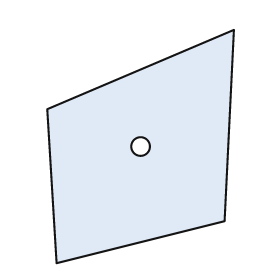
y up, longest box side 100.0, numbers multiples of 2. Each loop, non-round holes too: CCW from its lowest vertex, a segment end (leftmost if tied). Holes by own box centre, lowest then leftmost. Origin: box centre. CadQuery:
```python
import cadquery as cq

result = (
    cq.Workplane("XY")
    .moveTo(-36.0, -50.0)
    .lineTo(36.0, -32.0)
    .lineTo(40.0, 50.0)
    .lineTo(-40.0, 16.0)
    .close()
    .moveTo(0.0, 0.0)
    .circle(4.0)
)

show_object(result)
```